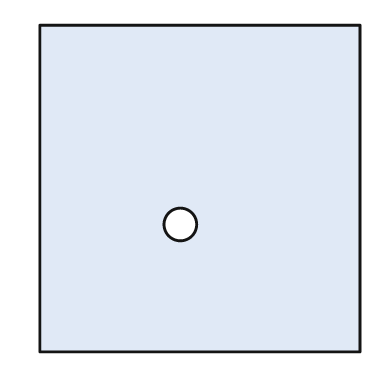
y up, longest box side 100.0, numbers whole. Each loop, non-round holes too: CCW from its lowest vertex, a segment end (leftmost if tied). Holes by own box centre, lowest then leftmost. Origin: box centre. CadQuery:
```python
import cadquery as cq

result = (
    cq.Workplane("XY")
    .moveTo(-49.0, -50.0)
    .lineTo(49.0, -50.0)
    .lineTo(49.0, 50.0)
    .lineTo(-49.0, 50.0)
    .close()
    .moveTo(-6.0, -11.0)
    .circle(5.0)
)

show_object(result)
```